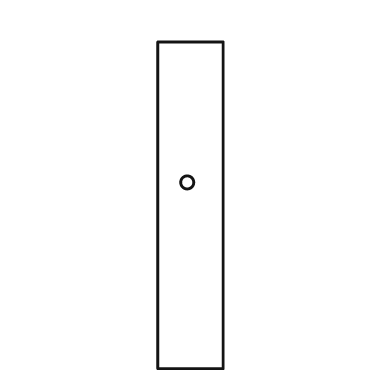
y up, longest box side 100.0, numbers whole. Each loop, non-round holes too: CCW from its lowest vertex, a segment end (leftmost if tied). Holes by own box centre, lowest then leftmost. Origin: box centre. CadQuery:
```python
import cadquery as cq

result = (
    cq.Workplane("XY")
    .moveTo(-10.0, -50.0)
    .lineTo(10.0, -50.0)
    .lineTo(10.0, 50.0)
    .lineTo(-10.0, 50.0)
    .close()
    .moveTo(-1.0, 7.0)
    .circle(2.0)
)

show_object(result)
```